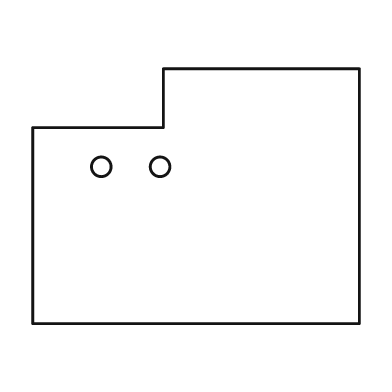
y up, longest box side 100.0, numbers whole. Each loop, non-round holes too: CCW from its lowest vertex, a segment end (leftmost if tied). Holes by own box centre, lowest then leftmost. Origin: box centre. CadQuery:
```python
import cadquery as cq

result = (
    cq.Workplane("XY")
    .moveTo(-50.0, -39.0)
    .lineTo(50.0, -39.0)
    .lineTo(50.0, 39.0)
    .lineTo(-10.0, 39.0)
    .lineTo(-10.0, 21.0)
    .lineTo(-50.0, 21.0)
    .close()
    .moveTo(-29.0, 9.0)
    .circle(3.0)
    .moveTo(-11.0, 9.0)
    .circle(3.0)
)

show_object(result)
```